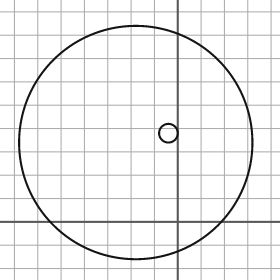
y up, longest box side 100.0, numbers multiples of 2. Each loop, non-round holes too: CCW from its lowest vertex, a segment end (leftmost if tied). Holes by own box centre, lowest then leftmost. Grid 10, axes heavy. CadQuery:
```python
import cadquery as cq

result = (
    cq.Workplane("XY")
    .moveTo(-18.0, 34.0)
    .circle(50.0)
    .moveTo(-4.0, 38.0)
    .circle(4.0)
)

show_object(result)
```